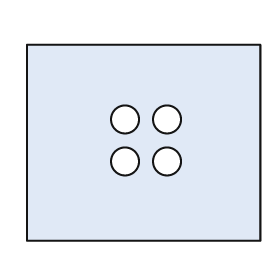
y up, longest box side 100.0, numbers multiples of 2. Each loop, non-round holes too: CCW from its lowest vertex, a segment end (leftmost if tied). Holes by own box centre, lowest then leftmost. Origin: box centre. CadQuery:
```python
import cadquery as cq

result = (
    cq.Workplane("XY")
    .moveTo(-50.0, -42.0)
    .lineTo(50.0, -42.0)
    .lineTo(50.0, 42.0)
    .lineTo(-50.0, 42.0)
    .close()
    .moveTo(-8.0, -8.0)
    .circle(6.0)
    .moveTo(10.0, -8.0)
    .circle(6.0)
    .moveTo(-8.0, 10.0)
    .circle(6.0)
    .moveTo(10.0, 10.0)
    .circle(6.0)
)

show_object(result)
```